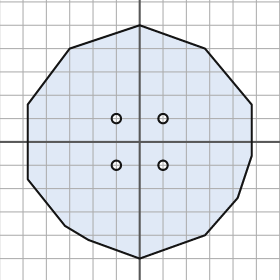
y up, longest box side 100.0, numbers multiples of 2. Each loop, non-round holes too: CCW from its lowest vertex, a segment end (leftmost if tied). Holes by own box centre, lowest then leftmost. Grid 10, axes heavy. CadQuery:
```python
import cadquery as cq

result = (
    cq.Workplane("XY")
    .moveTo(0.0, -50.0)
    .lineTo(28.0, -40.0)
    .lineTo(42.0, -24.0)
    .lineTo(48.0, -6.0)
    .lineTo(48.0, 16.0)
    .lineTo(28.0, 40.0)
    .lineTo(0.0, 50.0)
    .lineTo(-30.0, 40.0)
    .lineTo(-48.0, 16.0)
    .lineTo(-48.0, -16.0)
    .lineTo(-32.0, -36.0)
    .lineTo(-22.0, -42.0)
    .close()
    .moveTo(-10.0, -10.0)
    .circle(2.0)
    .moveTo(10.0, -10.0)
    .circle(2.0)
    .moveTo(-10.0, 10.0)
    .circle(2.0)
    .moveTo(10.0, 10.0)
    .circle(2.0)
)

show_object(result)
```